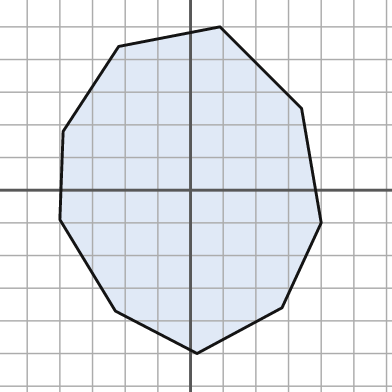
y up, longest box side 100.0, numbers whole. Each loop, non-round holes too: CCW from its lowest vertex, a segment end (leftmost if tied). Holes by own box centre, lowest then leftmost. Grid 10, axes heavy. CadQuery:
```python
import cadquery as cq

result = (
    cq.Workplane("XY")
    .moveTo(2.0, -50.0)
    .lineTo(28.0, -36.0)
    .lineTo(40.0, -10.0)
    .lineTo(34.0, 25.0)
    .lineTo(9.0, 50.0)
    .lineTo(-22.0, 44.0)
    .lineTo(-39.0, 18.0)
    .lineTo(-40.0, -9.0)
    .lineTo(-23.0, -37.0)
    .close()
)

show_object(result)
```